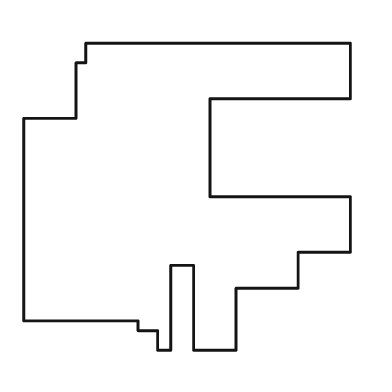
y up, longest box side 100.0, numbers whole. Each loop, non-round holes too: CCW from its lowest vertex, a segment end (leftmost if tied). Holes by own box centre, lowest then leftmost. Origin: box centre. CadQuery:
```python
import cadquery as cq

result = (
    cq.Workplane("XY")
    .moveTo(-9.0, -47.0)
    .lineTo(-5.0, -47.0)
    .lineTo(-5.0, -21.0)
    .lineTo(2.0, -21.0)
    .lineTo(2.0, -47.0)
    .lineTo(15.0, -47.0)
    .lineTo(15.0, -28.0)
    .lineTo(34.0, -28.0)
    .lineTo(34.0, -17.0)
    .lineTo(50.0, -17.0)
    .lineTo(50.0, 0.0)
    .lineTo(7.0, 0.0)
    .lineTo(7.0, 30.0)
    .lineTo(50.0, 30.0)
    .lineTo(50.0, 47.0)
    .lineTo(-31.0, 47.0)
    .lineTo(-31.0, 41.0)
    .lineTo(-34.0, 41.0)
    .lineTo(-34.0, 24.0)
    .lineTo(-50.0, 24.0)
    .lineTo(-50.0, -38.0)
    .lineTo(-15.0, -38.0)
    .lineTo(-15.0, -41.0)
    .lineTo(-9.0, -41.0)
    .close()
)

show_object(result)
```